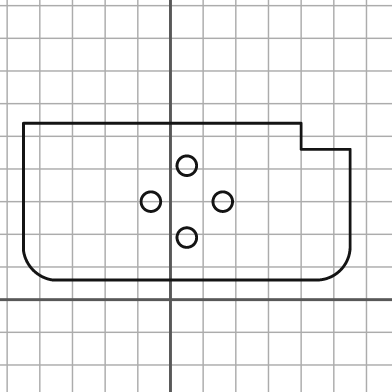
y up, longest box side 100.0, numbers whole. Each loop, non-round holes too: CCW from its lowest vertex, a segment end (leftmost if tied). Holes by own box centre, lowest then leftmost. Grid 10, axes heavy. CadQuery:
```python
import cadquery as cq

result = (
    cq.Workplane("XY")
    .moveTo(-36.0, 6.0)
    .lineTo(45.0, 6.0)
    .threePointArc((52.0, 9.0), (55.0, 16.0))
    .lineTo(55.0, 46.0)
    .lineTo(40.0, 46.0)
    .lineTo(40.0, 54.0)
    .lineTo(-45.0, 54.0)
    .lineTo(-45.0, 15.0)
    .threePointArc((-42.0, 9.0), (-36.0, 6.0))
    .close()
    .moveTo(5.0, 19.0)
    .circle(3.0)
    .moveTo(-6.0, 30.0)
    .circle(3.0)
    .moveTo(16.0, 30.0)
    .circle(3.0)
    .moveTo(5.0, 41.0)
    .circle(3.0)
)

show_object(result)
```